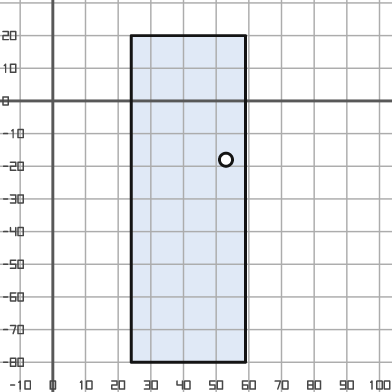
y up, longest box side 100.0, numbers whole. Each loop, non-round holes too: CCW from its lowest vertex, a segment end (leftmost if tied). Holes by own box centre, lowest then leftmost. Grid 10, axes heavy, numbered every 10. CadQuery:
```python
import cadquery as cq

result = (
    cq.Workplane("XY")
    .moveTo(24.0, -80.0)
    .lineTo(59.0, -80.0)
    .lineTo(59.0, 20.0)
    .lineTo(24.0, 20.0)
    .close()
    .moveTo(53.0, -18.0)
    .circle(2.0)
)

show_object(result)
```